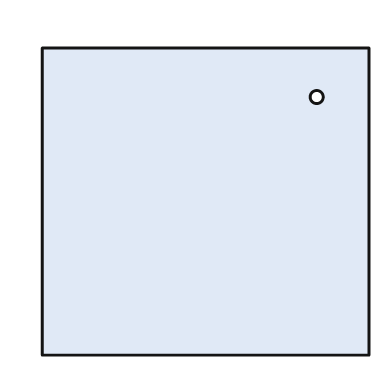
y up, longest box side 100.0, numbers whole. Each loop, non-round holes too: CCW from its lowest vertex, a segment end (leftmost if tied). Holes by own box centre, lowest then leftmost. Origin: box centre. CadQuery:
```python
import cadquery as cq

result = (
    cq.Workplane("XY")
    .moveTo(-50.0, -47.0)
    .lineTo(50.0, -47.0)
    .lineTo(50.0, 47.0)
    .lineTo(-50.0, 47.0)
    .close()
    .moveTo(34.0, 32.0)
    .circle(2.0)
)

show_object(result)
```